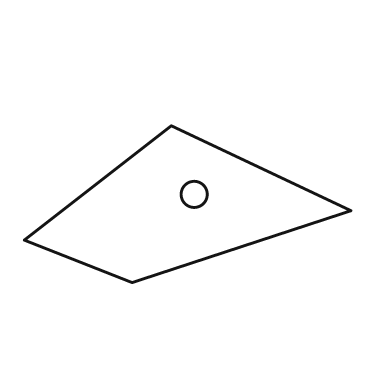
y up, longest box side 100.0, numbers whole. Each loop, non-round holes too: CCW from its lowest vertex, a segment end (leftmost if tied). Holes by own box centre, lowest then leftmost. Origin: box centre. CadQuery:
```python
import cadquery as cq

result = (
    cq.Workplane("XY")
    .moveTo(-17.0, -24.0)
    .lineTo(50.0, -2.0)
    .lineTo(-5.0, 24.0)
    .lineTo(-50.0, -11.0)
    .close()
    .moveTo(2.0, 3.0)
    .circle(4.0)
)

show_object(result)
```